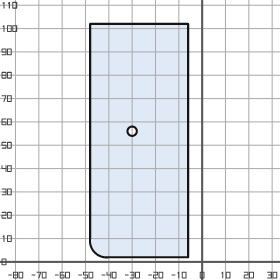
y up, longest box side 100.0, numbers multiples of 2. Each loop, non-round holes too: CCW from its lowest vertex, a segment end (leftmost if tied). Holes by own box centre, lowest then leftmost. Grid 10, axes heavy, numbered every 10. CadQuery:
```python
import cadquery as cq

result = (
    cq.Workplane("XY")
    .moveTo(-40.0, 2.0)
    .lineTo(-6.0, 2.0)
    .lineTo(-6.0, 102.0)
    .lineTo(-48.0, 102.0)
    .lineTo(-48.0, 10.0)
    .threePointArc((-46.0, 4.0), (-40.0, 2.0))
    .close()
    .moveTo(-30.0, 56.0)
    .circle(2.0)
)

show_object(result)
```